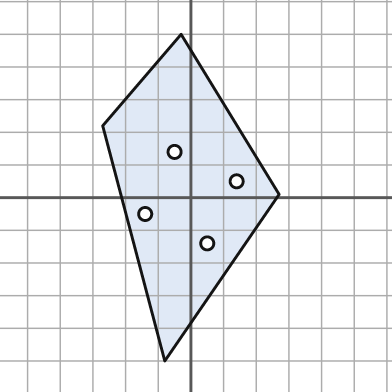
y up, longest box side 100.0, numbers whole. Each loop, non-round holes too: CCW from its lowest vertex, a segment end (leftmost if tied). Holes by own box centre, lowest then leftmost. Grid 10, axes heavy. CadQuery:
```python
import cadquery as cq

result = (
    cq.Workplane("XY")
    .moveTo(-8.0, -50.0)
    .lineTo(27.0, 1.0)
    .lineTo(-3.0, 50.0)
    .lineTo(-27.0, 22.0)
    .close()
    .moveTo(5.0, -14.0)
    .circle(2.0)
    .moveTo(-14.0, -5.0)
    .circle(2.0)
    .moveTo(14.0, 5.0)
    .circle(2.0)
    .moveTo(-5.0, 14.0)
    .circle(2.0)
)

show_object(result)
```